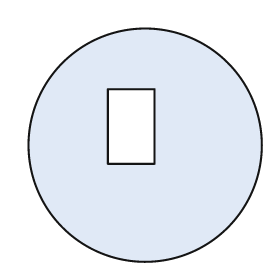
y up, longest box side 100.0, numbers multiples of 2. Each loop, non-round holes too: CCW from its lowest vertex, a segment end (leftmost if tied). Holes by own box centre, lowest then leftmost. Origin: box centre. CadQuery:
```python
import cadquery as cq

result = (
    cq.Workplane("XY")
    .moveTo(0.0, 0.0)
    .circle(50.0)
    .moveTo(-16.0, -8.0)
    .lineTo(4.0, -8.0)
    .lineTo(4.0, 24.0)
    .lineTo(-16.0, 24.0)
    .close()
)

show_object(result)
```